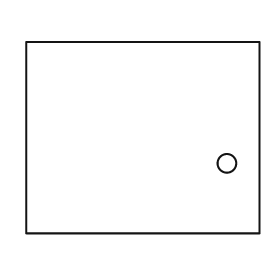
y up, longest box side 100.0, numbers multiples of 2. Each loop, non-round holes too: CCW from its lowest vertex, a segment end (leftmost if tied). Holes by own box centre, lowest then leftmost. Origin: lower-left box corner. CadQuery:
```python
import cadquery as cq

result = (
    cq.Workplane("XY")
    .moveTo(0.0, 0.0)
    .lineTo(100.0, 0.0)
    .lineTo(100.0, 82.0)
    .lineTo(0.0, 82.0)
    .close()
    .moveTo(86.0, 30.0)
    .circle(4.0)
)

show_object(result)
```